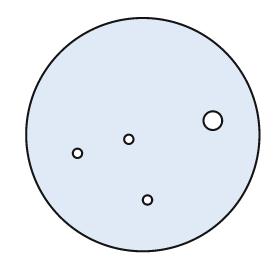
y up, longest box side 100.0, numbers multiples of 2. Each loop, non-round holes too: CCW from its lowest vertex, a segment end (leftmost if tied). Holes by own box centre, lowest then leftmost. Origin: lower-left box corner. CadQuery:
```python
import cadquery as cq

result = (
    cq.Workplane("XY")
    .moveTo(50.0, 50.0)
    .circle(50.0)
    .moveTo(52.0, 22.0)
    .circle(2.0)
    .moveTo(22.0, 42.0)
    .circle(2.0)
    .moveTo(44.0, 48.0)
    .circle(2.0)
    .moveTo(80.0, 56.0)
    .circle(4.0)
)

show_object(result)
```